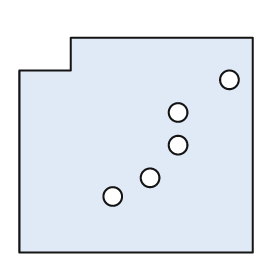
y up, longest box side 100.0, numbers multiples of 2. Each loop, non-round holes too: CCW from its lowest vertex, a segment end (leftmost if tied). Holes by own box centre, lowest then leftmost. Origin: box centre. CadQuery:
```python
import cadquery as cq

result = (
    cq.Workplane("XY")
    .moveTo(-50.0, -46.0)
    .lineTo(50.0, -46.0)
    .lineTo(50.0, 46.0)
    .lineTo(-28.0, 46.0)
    .lineTo(-28.0, 32.0)
    .lineTo(-50.0, 32.0)
    .close()
    .moveTo(-10.0, -22.0)
    .circle(4.0)
    .moveTo(6.0, -14.0)
    .circle(4.0)
    .moveTo(18.0, 0.0)
    .circle(4.0)
    .moveTo(18.0, 14.0)
    .circle(4.0)
    .moveTo(40.0, 28.0)
    .circle(4.0)
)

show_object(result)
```